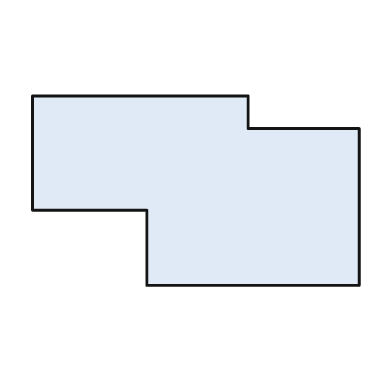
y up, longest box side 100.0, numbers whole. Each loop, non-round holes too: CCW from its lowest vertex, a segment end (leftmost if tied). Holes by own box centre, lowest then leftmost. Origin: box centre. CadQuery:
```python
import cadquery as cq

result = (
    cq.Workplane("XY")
    .moveTo(-15.0, -29.0)
    .lineTo(50.0, -29.0)
    .lineTo(50.0, 19.0)
    .lineTo(16.0, 19.0)
    .lineTo(16.0, 29.0)
    .lineTo(-50.0, 29.0)
    .lineTo(-50.0, -6.0)
    .lineTo(-15.0, -6.0)
    .close()
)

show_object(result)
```